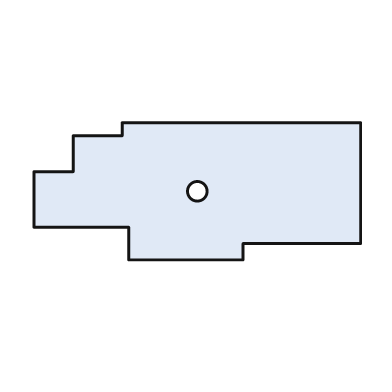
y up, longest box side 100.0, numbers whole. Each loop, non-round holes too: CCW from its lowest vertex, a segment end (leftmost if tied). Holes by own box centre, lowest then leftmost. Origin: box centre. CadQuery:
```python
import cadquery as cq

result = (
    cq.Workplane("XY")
    .moveTo(-21.0, -21.0)
    .lineTo(14.0, -21.0)
    .lineTo(14.0, -16.0)
    .lineTo(50.0, -16.0)
    .lineTo(50.0, 21.0)
    .lineTo(-23.0, 21.0)
    .lineTo(-23.0, 17.0)
    .lineTo(-38.0, 17.0)
    .lineTo(-38.0, 6.0)
    .lineTo(-50.0, 6.0)
    .lineTo(-50.0, -11.0)
    .lineTo(-21.0, -11.0)
    .close()
    .moveTo(0.0, 0.0)
    .circle(3.0)
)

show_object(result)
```